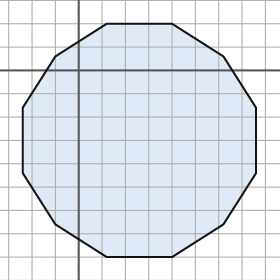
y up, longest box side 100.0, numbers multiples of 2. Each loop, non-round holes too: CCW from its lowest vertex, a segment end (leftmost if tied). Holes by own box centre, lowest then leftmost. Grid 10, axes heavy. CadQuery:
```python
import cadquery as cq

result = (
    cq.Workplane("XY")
    .moveTo(12.0, -80.0)
    .lineTo(40.0, -80.0)
    .lineTo(62.0, -66.0)
    .lineTo(76.0, -44.0)
    .lineTo(76.0, -16.0)
    .lineTo(62.0, 6.0)
    .lineTo(40.0, 20.0)
    .lineTo(12.0, 20.0)
    .lineTo(-10.0, 6.0)
    .lineTo(-24.0, -16.0)
    .lineTo(-24.0, -44.0)
    .lineTo(-10.0, -66.0)
    .close()
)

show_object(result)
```